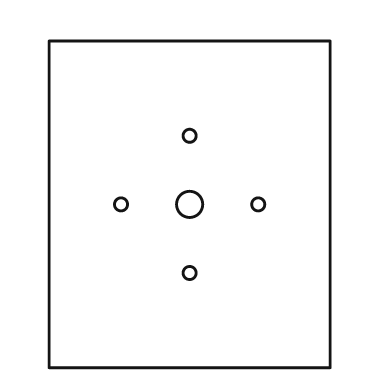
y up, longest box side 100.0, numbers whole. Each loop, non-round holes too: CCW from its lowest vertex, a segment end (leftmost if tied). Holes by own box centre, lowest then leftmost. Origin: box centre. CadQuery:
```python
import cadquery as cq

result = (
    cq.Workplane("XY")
    .moveTo(-43.0, -50.0)
    .lineTo(43.0, -50.0)
    .lineTo(43.0, 50.0)
    .lineTo(-43.0, 50.0)
    .close()
    .moveTo(0.0, -21.0)
    .circle(2.0)
    .moveTo(-21.0, 0.0)
    .circle(2.0)
    .moveTo(0.0, 0.0)
    .circle(4.0)
    .moveTo(21.0, 0.0)
    .circle(2.0)
    .moveTo(0.0, 21.0)
    .circle(2.0)
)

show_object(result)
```